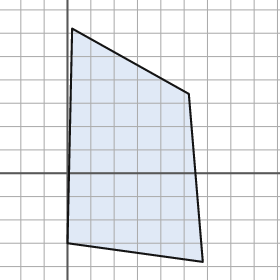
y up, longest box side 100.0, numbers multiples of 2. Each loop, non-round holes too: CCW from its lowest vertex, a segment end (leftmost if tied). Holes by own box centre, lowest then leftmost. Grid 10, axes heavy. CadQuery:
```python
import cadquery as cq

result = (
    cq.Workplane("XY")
    .moveTo(58.0, -38.0)
    .lineTo(52.0, 34.0)
    .lineTo(2.0, 62.0)
    .lineTo(0.0, -30.0)
    .close()
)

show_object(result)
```